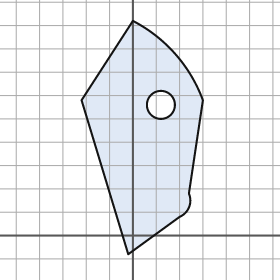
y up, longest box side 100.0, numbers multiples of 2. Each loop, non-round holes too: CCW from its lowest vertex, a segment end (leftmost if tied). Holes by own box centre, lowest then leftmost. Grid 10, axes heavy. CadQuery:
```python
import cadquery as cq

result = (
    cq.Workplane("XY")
    .moveTo(-2.0, -8.0)
    .lineTo(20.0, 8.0)
    .threePointArc((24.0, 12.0), (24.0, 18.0))
    .lineTo(30.0, 58.0)
    .threePointArc((18.0, 78.0), (0.0, 92.0))
    .lineTo(-22.0, 58.0)
    .close()
    .moveTo(12.0, 56.0)
    .circle(6.0)
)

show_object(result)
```